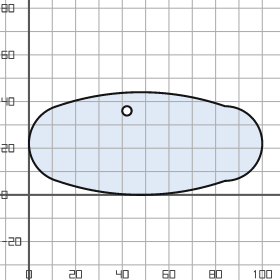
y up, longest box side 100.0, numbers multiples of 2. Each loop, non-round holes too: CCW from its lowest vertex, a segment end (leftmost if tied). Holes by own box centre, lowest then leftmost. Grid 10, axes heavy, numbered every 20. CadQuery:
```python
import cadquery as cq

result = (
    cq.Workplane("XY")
    .moveTo(12.0, 6.0)
    .threePointArc((48.0, 0.0), (84.0, 6.0))
    .threePointArc((100.0, 22.0), (84.0, 38.0))
    .threePointArc((48.0, 44.0), (12.0, 38.0))
    .threePointArc((0.0, 22.0), (12.0, 6.0))
    .close()
    .moveTo(42.0, 36.0)
    .circle(2.0)
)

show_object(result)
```